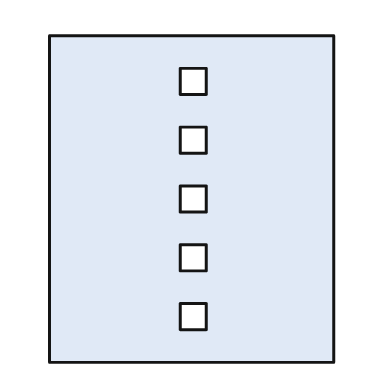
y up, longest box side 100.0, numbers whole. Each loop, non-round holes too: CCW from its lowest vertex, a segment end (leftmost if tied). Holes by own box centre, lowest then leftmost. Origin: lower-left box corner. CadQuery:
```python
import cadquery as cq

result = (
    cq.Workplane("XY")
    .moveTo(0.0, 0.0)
    .lineTo(87.0, 0.0)
    .lineTo(87.0, 100.0)
    .lineTo(0.0, 100.0)
    .close()
    .moveTo(40.0, 10.0)
    .lineTo(48.0, 10.0)
    .lineTo(48.0, 18.0)
    .lineTo(40.0, 18.0)
    .close()
    .moveTo(40.0, 28.0)
    .lineTo(48.0, 28.0)
    .lineTo(48.0, 36.0)
    .lineTo(40.0, 36.0)
    .close()
    .moveTo(40.0, 46.0)
    .lineTo(48.0, 46.0)
    .lineTo(48.0, 54.0)
    .lineTo(40.0, 54.0)
    .close()
    .moveTo(40.0, 64.0)
    .lineTo(48.0, 64.0)
    .lineTo(48.0, 72.0)
    .lineTo(40.0, 72.0)
    .close()
    .moveTo(40.0, 82.0)
    .lineTo(48.0, 82.0)
    .lineTo(48.0, 90.0)
    .lineTo(40.0, 90.0)
    .close()
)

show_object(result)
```